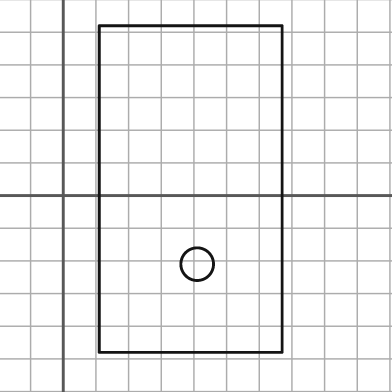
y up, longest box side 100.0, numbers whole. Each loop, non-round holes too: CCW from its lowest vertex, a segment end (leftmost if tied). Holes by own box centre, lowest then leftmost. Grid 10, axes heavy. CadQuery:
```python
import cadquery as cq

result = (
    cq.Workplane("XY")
    .moveTo(11.0, -48.0)
    .lineTo(67.0, -48.0)
    .lineTo(67.0, 52.0)
    .lineTo(11.0, 52.0)
    .close()
    .moveTo(41.0, -21.0)
    .circle(5.0)
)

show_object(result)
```